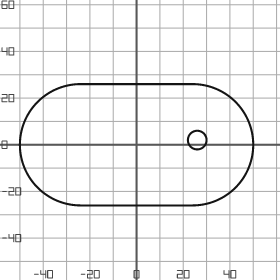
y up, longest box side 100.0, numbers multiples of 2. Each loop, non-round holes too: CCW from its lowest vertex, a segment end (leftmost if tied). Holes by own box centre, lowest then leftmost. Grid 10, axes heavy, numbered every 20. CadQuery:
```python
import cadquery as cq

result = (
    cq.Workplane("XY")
    .moveTo(-24.0, -26.0)
    .lineTo(24.0, -26.0)
    .threePointArc((50.0, 0.0), (24.0, 26.0))
    .lineTo(-24.0, 26.0)
    .threePointArc((-50.0, 0.0), (-24.0, -26.0))
    .close()
    .moveTo(26.0, 2.0)
    .circle(4.0)
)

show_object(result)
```